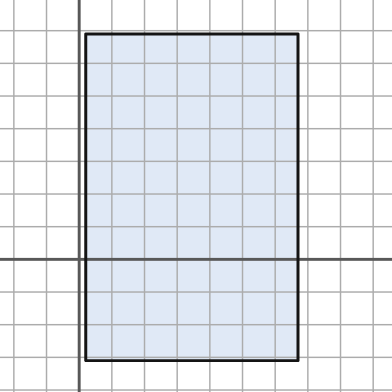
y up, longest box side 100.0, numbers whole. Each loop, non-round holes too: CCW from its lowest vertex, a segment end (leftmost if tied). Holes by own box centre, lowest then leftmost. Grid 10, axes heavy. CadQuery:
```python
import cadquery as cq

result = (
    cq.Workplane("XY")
    .moveTo(2.0, -31.0)
    .lineTo(67.0, -31.0)
    .lineTo(67.0, 69.0)
    .lineTo(2.0, 69.0)
    .close()
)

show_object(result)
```